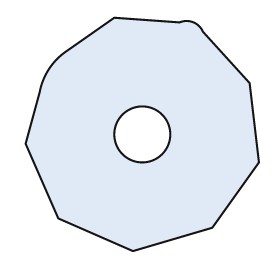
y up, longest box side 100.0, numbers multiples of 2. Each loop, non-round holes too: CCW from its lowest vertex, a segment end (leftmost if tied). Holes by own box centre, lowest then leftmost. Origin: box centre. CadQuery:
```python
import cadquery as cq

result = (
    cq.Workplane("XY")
    .moveTo(-4.0, -50.0)
    .lineTo(30.0, -40.0)
    .lineTo(50.0, -12.0)
    .lineTo(46.0, 22.0)
    .lineTo(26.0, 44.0)
    .threePointArc((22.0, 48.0), (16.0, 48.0))
    .lineTo(-12.0, 50.0)
    .lineTo(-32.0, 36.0)
    .threePointArc((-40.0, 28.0), (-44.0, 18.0))
    .lineTo(-50.0, -4.0)
    .lineTo(-36.0, -36.0)
    .close()
    .moveTo(0.0, 0.0)
    .circle(12.0)
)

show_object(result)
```